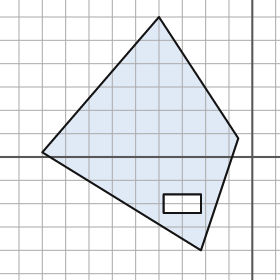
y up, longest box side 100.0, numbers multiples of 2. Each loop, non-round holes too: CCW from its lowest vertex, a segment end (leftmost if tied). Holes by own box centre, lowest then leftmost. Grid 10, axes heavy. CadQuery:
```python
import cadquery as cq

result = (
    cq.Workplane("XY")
    .moveTo(-22.0, -40.0)
    .lineTo(-6.0, 8.0)
    .lineTo(-40.0, 60.0)
    .lineTo(-90.0, 2.0)
    .close()
    .moveTo(-38.0, -24.0)
    .lineTo(-22.0, -24.0)
    .lineTo(-22.0, -16.0)
    .lineTo(-38.0, -16.0)
    .close()
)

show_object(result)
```